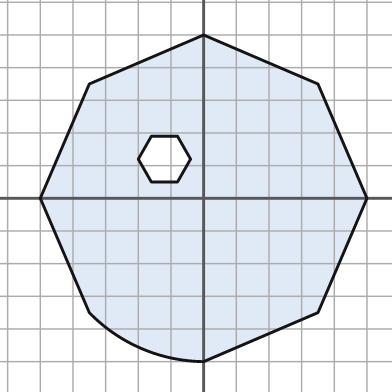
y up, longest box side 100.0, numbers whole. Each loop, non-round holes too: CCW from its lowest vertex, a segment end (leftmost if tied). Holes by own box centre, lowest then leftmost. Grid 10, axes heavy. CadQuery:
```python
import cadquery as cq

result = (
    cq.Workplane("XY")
    .moveTo(0.0, -50.0)
    .lineTo(35.0, -35.0)
    .lineTo(50.0, 0.0)
    .lineTo(35.0, 35.0)
    .lineTo(0.0, 50.0)
    .lineTo(-35.0, 35.0)
    .lineTo(-50.0, 0.0)
    .lineTo(-35.0, -35.0)
    .threePointArc((-19.0, -46.0), (0.0, -50.0))
    .close()
    .moveTo(-16.0, 5.0)
    .lineTo(-8.0, 5.0)
    .lineTo(-4.0, 12.0)
    .lineTo(-8.0, 19.0)
    .lineTo(-16.0, 19.0)
    .lineTo(-20.0, 12.0)
    .close()
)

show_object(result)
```